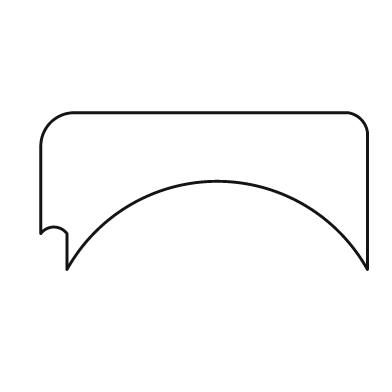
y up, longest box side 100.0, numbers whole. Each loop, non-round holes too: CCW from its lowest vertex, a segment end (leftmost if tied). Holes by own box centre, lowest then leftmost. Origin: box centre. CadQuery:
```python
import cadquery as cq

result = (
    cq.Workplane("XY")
    .moveTo(-42.0, -24.0)
    .threePointArc((4.0, 3.0), (50.0, -24.0))
    .lineTo(50.0, 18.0)
    .threePointArc((48.0, 22.0), (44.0, 24.0))
    .lineTo(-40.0, 24.0)
    .threePointArc((-47.0, 21.0), (-50.0, 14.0))
    .lineTo(-50.0, -13.0)
    .threePointArc((-46.0, -11.0), (-42.0, -13.0))
    .close()
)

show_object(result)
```